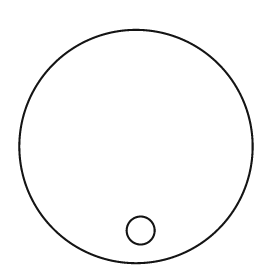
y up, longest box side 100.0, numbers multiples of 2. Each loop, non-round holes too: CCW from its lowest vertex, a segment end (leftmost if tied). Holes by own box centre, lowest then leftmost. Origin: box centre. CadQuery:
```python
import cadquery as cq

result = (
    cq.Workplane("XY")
    .moveTo(0.0, 0.0)
    .circle(50.0)
    .moveTo(2.0, -36.0)
    .circle(6.0)
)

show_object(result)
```